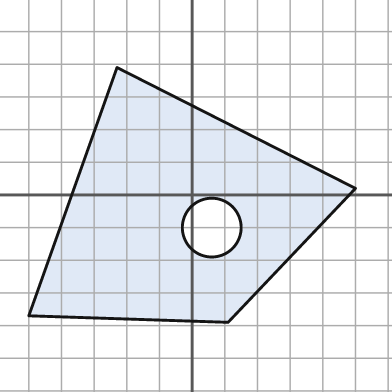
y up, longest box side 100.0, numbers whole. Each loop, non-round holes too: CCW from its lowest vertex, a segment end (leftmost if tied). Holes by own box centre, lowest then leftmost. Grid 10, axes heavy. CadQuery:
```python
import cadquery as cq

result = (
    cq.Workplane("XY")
    .moveTo(11.0, -39.0)
    .lineTo(50.0, 2.0)
    .lineTo(-23.0, 39.0)
    .lineTo(-50.0, -37.0)
    .close()
    .moveTo(6.0, -10.0)
    .circle(9.0)
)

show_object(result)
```